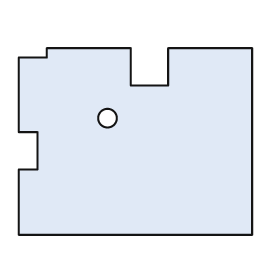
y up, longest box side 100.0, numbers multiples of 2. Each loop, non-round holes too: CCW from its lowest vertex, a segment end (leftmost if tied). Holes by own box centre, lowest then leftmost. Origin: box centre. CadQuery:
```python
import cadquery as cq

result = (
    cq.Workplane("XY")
    .moveTo(-50.0, -40.0)
    .lineTo(50.0, -40.0)
    .lineTo(50.0, 40.0)
    .lineTo(14.0, 40.0)
    .lineTo(14.0, 24.0)
    .lineTo(-2.0, 24.0)
    .lineTo(-2.0, 40.0)
    .lineTo(-38.0, 40.0)
    .lineTo(-38.0, 36.0)
    .lineTo(-50.0, 36.0)
    .lineTo(-50.0, 4.0)
    .lineTo(-42.0, 4.0)
    .lineTo(-42.0, -12.0)
    .lineTo(-50.0, -12.0)
    .close()
    .moveTo(-12.0, 10.0)
    .circle(4.0)
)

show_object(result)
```